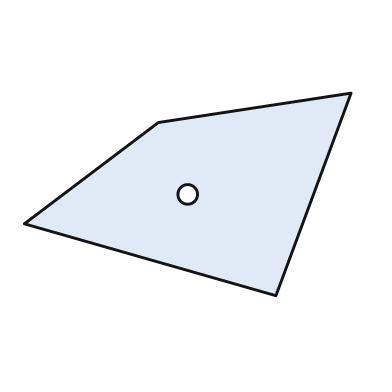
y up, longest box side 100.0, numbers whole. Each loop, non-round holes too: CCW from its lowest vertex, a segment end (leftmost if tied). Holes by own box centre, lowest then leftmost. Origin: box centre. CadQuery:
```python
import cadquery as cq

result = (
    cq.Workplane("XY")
    .moveTo(27.0, -31.0)
    .lineTo(50.0, 31.0)
    .lineTo(-9.0, 22.0)
    .lineTo(-50.0, -9.0)
    .close()
    .moveTo(0.0, 0.0)
    .circle(3.0)
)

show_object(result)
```